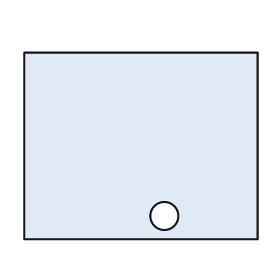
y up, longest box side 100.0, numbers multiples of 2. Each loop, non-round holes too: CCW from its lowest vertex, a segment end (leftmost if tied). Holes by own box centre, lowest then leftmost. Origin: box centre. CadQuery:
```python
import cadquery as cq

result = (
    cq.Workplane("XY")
    .moveTo(-50.0, -40.0)
    .lineTo(50.0, -40.0)
    .lineTo(50.0, 40.0)
    .lineTo(-50.0, 40.0)
    .close()
    .moveTo(10.0, -30.0)
    .circle(6.0)
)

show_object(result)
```